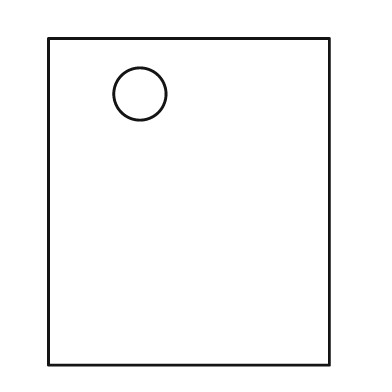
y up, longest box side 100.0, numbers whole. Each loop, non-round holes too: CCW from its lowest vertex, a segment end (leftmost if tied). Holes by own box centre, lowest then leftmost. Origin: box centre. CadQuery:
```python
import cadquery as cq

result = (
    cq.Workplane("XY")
    .moveTo(-43.0, -50.0)
    .lineTo(43.0, -50.0)
    .lineTo(43.0, 50.0)
    .lineTo(-43.0, 50.0)
    .close()
    .moveTo(-15.0, 33.0)
    .circle(8.0)
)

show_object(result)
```